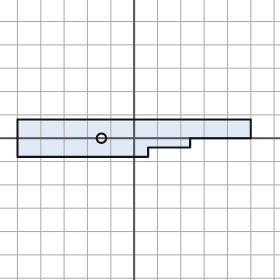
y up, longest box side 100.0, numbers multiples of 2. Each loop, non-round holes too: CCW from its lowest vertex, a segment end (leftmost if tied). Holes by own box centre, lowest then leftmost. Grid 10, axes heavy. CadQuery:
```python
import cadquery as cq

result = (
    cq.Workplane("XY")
    .moveTo(-50.0, -8.0)
    .lineTo(6.0, -8.0)
    .lineTo(6.0, -4.0)
    .lineTo(24.0, -4.0)
    .lineTo(24.0, 0.0)
    .lineTo(50.0, 0.0)
    .lineTo(50.0, 8.0)
    .lineTo(-50.0, 8.0)
    .close()
    .moveTo(-14.0, 0.0)
    .circle(2.0)
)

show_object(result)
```